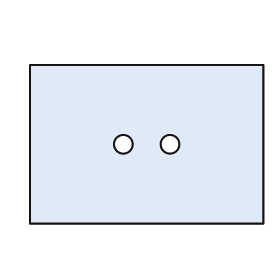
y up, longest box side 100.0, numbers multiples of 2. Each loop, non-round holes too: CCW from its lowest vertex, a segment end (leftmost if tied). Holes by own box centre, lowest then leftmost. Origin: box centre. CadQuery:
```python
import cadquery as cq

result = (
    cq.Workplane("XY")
    .moveTo(-50.0, -34.0)
    .lineTo(50.0, -34.0)
    .lineTo(50.0, 34.0)
    .lineTo(-50.0, 34.0)
    .close()
    .moveTo(-10.0, 0.0)
    .circle(4.0)
    .moveTo(10.0, 0.0)
    .circle(4.0)
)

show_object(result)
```